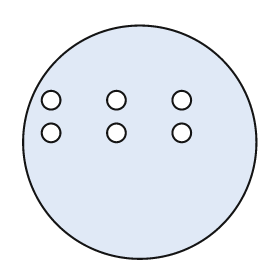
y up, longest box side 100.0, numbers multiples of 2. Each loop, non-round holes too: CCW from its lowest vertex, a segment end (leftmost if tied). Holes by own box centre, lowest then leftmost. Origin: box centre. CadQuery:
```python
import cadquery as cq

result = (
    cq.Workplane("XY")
    .moveTo(0.0, 0.0)
    .circle(50.0)
    .moveTo(-38.0, 4.0)
    .circle(4.0)
    .moveTo(-10.0, 4.0)
    .circle(4.0)
    .moveTo(18.0, 4.0)
    .circle(4.0)
    .moveTo(-38.0, 18.0)
    .circle(4.0)
    .moveTo(-10.0, 18.0)
    .circle(4.0)
    .moveTo(18.0, 18.0)
    .circle(4.0)
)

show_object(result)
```